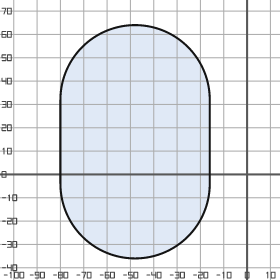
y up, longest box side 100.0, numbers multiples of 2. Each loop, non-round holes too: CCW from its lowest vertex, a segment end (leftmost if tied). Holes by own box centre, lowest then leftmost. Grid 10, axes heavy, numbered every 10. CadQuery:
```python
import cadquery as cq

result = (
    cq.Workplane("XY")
    .moveTo(-80.0, -4.0)
    .threePointArc((-48.0, -36.0), (-16.0, -4.0))
    .lineTo(-16.0, 32.0)
    .threePointArc((-48.0, 64.0), (-80.0, 32.0))
    .close()
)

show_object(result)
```